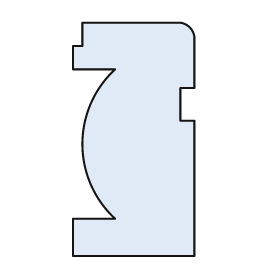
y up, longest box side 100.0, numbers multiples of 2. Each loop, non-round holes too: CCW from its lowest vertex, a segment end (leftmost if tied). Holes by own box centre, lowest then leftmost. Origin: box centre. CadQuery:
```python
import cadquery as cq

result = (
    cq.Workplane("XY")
    .moveTo(-26.0, -50.0)
    .lineTo(26.0, -50.0)
    .lineTo(26.0, 8.0)
    .lineTo(20.0, 8.0)
    .lineTo(20.0, 22.0)
    .lineTo(26.0, 22.0)
    .lineTo(26.0, 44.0)
    .threePointArc((24.0, 48.0), (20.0, 50.0))
    .lineTo(-22.0, 50.0)
    .lineTo(-22.0, 40.0)
    .lineTo(-26.0, 40.0)
    .lineTo(-26.0, 30.0)
    .lineTo(-8.0, 30.0)
    .threePointArc((-22.0, -2.0), (-8.0, -34.0))
    .lineTo(-26.0, -34.0)
    .close()
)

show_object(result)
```